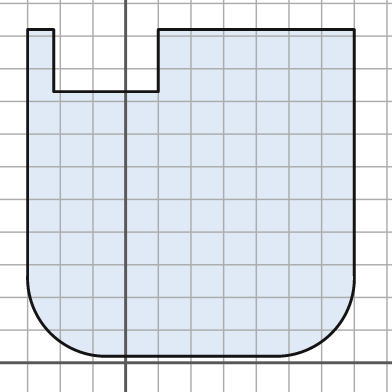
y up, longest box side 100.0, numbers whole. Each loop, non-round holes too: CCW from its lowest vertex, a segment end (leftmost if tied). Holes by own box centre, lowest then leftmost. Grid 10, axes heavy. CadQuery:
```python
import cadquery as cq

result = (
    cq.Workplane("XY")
    .moveTo(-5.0, 2.0)
    .lineTo(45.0, 2.0)
    .threePointArc((63.0, 9.0), (70.0, 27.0))
    .lineTo(70.0, 102.0)
    .lineTo(10.0, 102.0)
    .lineTo(10.0, 83.0)
    .lineTo(-22.0, 83.0)
    .lineTo(-22.0, 102.0)
    .lineTo(-30.0, 102.0)
    .lineTo(-30.0, 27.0)
    .threePointArc((-23.0, 9.0), (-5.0, 2.0))
    .close()
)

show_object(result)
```